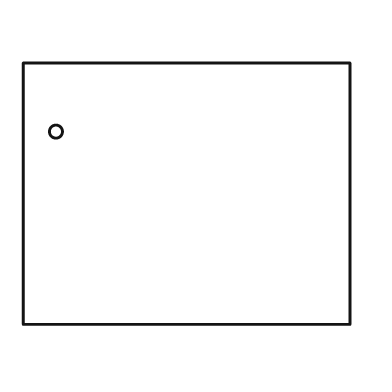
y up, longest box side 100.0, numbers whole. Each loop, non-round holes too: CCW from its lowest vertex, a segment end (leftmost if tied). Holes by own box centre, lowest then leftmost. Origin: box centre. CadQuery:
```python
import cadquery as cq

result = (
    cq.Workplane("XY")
    .moveTo(-50.0, -40.0)
    .lineTo(50.0, -40.0)
    .lineTo(50.0, 40.0)
    .lineTo(-50.0, 40.0)
    .close()
    .moveTo(-40.0, 19.0)
    .circle(2.0)
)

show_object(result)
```